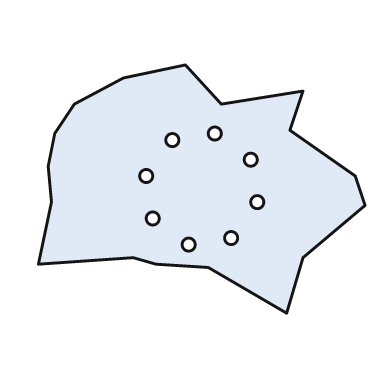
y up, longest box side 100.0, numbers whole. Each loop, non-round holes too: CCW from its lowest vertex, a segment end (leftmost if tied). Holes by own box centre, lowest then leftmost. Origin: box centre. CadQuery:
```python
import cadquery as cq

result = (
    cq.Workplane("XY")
    .moveTo(26.0, -38.0)
    .lineTo(31.0, -21.0)
    .lineTo(50.0, -5.0)
    .lineTo(47.0, 4.0)
    .lineTo(27.0, 18.0)
    .lineTo(31.0, 30.0)
    .lineTo(6.0, 26.0)
    .lineTo(-5.0, 38.0)
    .lineTo(-24.0, 34.0)
    .lineTo(-39.0, 26.0)
    .lineTo(-45.0, 17.0)
    .lineTo(-47.0, 7.0)
    .lineTo(-46.0, -4.0)
    .lineTo(-50.0, -23.0)
    .lineTo(-21.0, -21.0)
    .lineTo(-14.0, -23.0)
    .lineTo(2.0, -24.0)
    .close()
    .moveTo(-4.0, -17.0)
    .circle(2.0)
    .moveTo(9.0, -15.0)
    .circle(2.0)
    .moveTo(-15.0, -9.0)
    .circle(2.0)
    .moveTo(17.0, -4.0)
    .circle(2.0)
    .moveTo(-17.0, 4.0)
    .circle(2.0)
    .moveTo(15.0, 9.0)
    .circle(2.0)
    .moveTo(-9.0, 15.0)
    .circle(2.0)
    .moveTo(4.0, 17.0)
    .circle(2.0)
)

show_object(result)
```